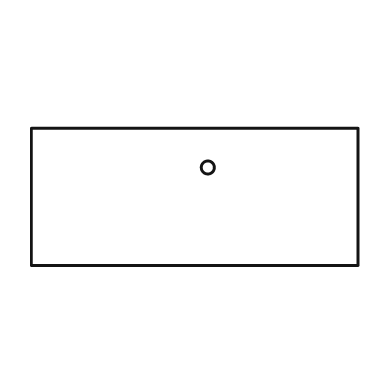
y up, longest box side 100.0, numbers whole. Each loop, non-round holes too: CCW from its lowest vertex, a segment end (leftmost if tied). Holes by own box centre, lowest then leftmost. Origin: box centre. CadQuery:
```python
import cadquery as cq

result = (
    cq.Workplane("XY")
    .moveTo(-50.0, -21.0)
    .lineTo(50.0, -21.0)
    .lineTo(50.0, 21.0)
    .lineTo(-50.0, 21.0)
    .close()
    .moveTo(4.0, 9.0)
    .circle(2.0)
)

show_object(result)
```